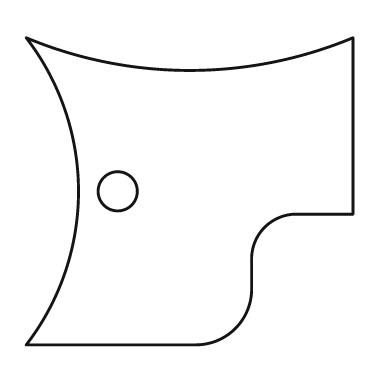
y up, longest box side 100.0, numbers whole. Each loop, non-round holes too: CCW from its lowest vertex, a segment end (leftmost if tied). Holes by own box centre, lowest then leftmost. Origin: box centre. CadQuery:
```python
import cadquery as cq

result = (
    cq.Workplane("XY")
    .moveTo(-50.0, -47.0)
    .lineTo(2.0, -47.0)
    .threePointArc((14.0, -42.0), (19.0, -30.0))
    .lineTo(19.0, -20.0)
    .threePointArc((23.0, -11.0), (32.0, -7.0))
    .lineTo(50.0, -7.0)
    .lineTo(50.0, 47.0)
    .threePointArc((0.0, 37.0), (-50.0, 47.0))
    .threePointArc((-34.0, 0.0), (-50.0, -47.0))
    .close()
    .moveTo(-22.0, 0.0)
    .circle(6.0)
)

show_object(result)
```